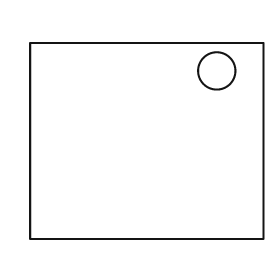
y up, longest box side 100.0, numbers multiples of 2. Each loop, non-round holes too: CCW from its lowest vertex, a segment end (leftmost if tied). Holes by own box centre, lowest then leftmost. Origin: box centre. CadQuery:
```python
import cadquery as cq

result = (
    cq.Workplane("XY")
    .moveTo(-50.0, -42.0)
    .lineTo(50.0, -42.0)
    .lineTo(50.0, 42.0)
    .lineTo(-50.0, 42.0)
    .close()
    .moveTo(30.0, 30.0)
    .circle(8.0)
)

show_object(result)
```